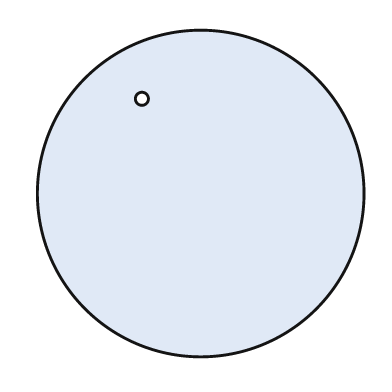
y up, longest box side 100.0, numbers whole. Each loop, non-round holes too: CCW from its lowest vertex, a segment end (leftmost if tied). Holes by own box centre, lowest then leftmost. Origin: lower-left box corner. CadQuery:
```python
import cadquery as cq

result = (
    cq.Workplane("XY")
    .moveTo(50.0, 50.0)
    .circle(50.0)
    .moveTo(32.0, 79.0)
    .circle(2.0)
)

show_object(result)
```